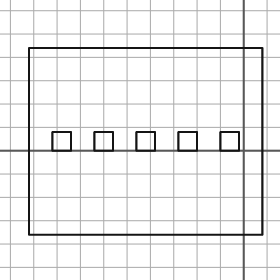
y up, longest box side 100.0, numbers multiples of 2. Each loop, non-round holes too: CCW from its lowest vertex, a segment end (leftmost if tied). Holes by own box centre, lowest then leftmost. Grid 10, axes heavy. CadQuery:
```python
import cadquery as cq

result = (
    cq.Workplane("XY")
    .moveTo(-92.0, -36.0)
    .lineTo(8.0, -36.0)
    .lineTo(8.0, 44.0)
    .lineTo(-92.0, 44.0)
    .close()
    .moveTo(-82.0, 0.0)
    .lineTo(-74.0, 0.0)
    .lineTo(-74.0, 8.0)
    .lineTo(-82.0, 8.0)
    .close()
    .moveTo(-64.0, 0.0)
    .lineTo(-56.0, 0.0)
    .lineTo(-56.0, 8.0)
    .lineTo(-64.0, 8.0)
    .close()
    .moveTo(-46.0, 0.0)
    .lineTo(-38.0, 0.0)
    .lineTo(-38.0, 8.0)
    .lineTo(-46.0, 8.0)
    .close()
    .moveTo(-28.0, 0.0)
    .lineTo(-20.0, 0.0)
    .lineTo(-20.0, 8.0)
    .lineTo(-28.0, 8.0)
    .close()
    .moveTo(-10.0, 0.0)
    .lineTo(-2.0, 0.0)
    .lineTo(-2.0, 8.0)
    .lineTo(-10.0, 8.0)
    .close()
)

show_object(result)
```